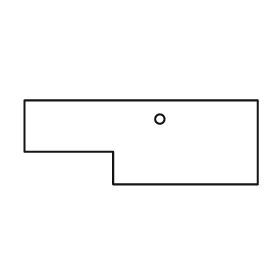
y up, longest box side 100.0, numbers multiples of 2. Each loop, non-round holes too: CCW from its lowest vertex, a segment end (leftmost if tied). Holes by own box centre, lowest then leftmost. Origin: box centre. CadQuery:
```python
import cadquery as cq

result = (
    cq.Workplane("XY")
    .moveTo(-12.0, -18.0)
    .lineTo(50.0, -18.0)
    .lineTo(50.0, 18.0)
    .lineTo(-50.0, 18.0)
    .lineTo(-50.0, -4.0)
    .lineTo(-12.0, -4.0)
    .close()
    .moveTo(8.0, 10.0)
    .circle(2.0)
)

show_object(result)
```